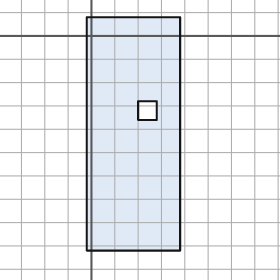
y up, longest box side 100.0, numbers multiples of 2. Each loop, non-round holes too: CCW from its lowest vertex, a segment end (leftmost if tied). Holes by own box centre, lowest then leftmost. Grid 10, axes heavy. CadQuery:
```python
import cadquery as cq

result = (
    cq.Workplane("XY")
    .moveTo(-2.0, -92.0)
    .lineTo(38.0, -92.0)
    .lineTo(38.0, 8.0)
    .lineTo(-2.0, 8.0)
    .close()
    .moveTo(20.0, -36.0)
    .lineTo(28.0, -36.0)
    .lineTo(28.0, -28.0)
    .lineTo(20.0, -28.0)
    .close()
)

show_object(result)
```